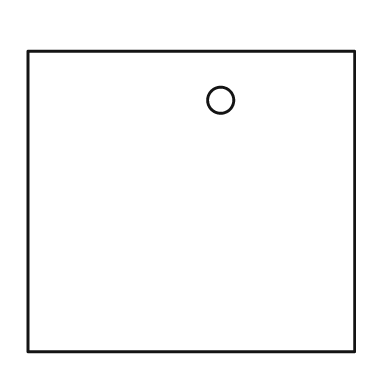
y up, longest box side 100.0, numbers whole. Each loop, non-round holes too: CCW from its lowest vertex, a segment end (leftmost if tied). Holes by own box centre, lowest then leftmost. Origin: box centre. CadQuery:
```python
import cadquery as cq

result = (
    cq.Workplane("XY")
    .moveTo(-50.0, -46.0)
    .lineTo(50.0, -46.0)
    .lineTo(50.0, 46.0)
    .lineTo(-50.0, 46.0)
    .close()
    .moveTo(9.0, 31.0)
    .circle(4.0)
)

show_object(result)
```